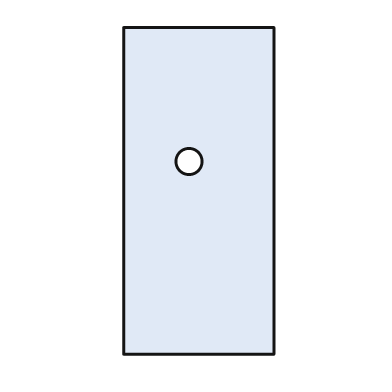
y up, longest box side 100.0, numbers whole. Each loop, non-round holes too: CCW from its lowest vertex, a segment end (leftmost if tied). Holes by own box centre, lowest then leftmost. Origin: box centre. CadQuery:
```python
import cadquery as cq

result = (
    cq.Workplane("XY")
    .moveTo(-23.0, -50.0)
    .lineTo(23.0, -50.0)
    .lineTo(23.0, 50.0)
    .lineTo(-23.0, 50.0)
    .close()
    .moveTo(-3.0, 9.0)
    .circle(4.0)
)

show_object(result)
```